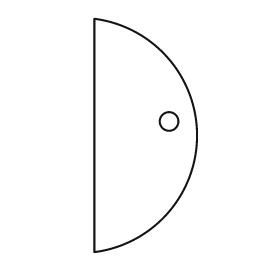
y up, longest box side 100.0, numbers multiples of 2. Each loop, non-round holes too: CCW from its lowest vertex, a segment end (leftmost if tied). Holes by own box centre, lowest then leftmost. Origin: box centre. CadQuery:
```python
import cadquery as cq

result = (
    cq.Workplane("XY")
    .moveTo(-22.0, -50.0)
    .threePointArc((22.0, 0.0), (-22.0, 50.0))
    .close()
    .moveTo(10.0, 6.0)
    .circle(4.0)
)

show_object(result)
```